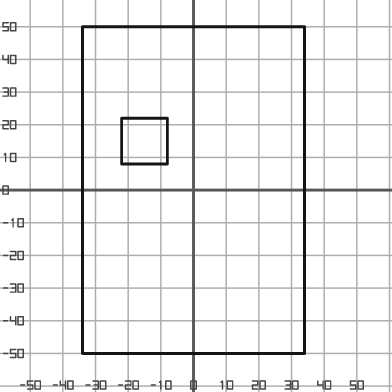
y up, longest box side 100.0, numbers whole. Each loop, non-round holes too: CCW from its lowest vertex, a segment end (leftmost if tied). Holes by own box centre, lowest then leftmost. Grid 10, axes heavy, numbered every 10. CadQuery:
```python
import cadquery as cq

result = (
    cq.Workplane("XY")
    .moveTo(-34.0, -50.0)
    .lineTo(34.0, -50.0)
    .lineTo(34.0, 50.0)
    .lineTo(-34.0, 50.0)
    .close()
    .moveTo(-22.0, 8.0)
    .lineTo(-8.0, 8.0)
    .lineTo(-8.0, 22.0)
    .lineTo(-22.0, 22.0)
    .close()
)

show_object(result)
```